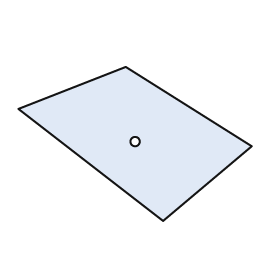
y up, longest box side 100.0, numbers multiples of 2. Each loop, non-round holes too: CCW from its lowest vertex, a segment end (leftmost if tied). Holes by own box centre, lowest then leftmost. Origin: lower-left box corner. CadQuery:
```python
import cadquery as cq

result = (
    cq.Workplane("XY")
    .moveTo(62.0, 0.0)
    .lineTo(100.0, 32.0)
    .lineTo(46.0, 66.0)
    .lineTo(0.0, 48.0)
    .close()
    .moveTo(50.0, 34.0)
    .circle(2.0)
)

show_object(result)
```